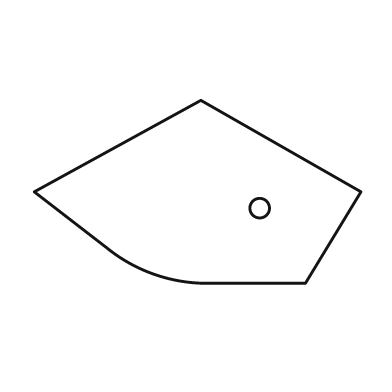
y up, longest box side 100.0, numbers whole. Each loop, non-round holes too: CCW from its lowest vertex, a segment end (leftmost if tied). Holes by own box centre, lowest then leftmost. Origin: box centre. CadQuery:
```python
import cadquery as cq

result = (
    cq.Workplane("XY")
    .moveTo(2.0, -28.0)
    .lineTo(33.0, -28.0)
    .lineTo(50.0, 0.0)
    .lineTo(1.0, 28.0)
    .lineTo(-50.0, 0.0)
    .lineTo(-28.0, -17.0)
    .threePointArc((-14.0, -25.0), (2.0, -28.0))
    .close()
    .moveTo(19.0, -5.0)
    .circle(3.0)
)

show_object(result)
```